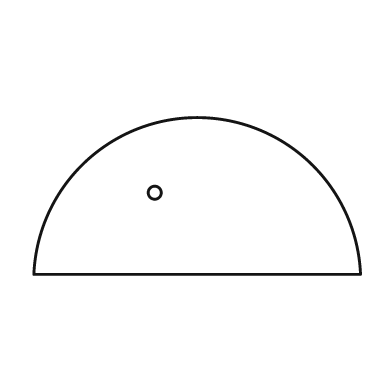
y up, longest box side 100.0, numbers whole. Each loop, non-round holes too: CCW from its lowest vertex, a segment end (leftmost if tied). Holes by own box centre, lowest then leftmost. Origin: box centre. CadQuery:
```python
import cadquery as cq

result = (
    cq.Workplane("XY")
    .moveTo(-50.0, -24.0)
    .lineTo(50.0, -24.0)
    .threePointArc((0.0, 24.0), (-50.0, -24.0))
    .close()
    .moveTo(-13.0, 1.0)
    .circle(2.0)
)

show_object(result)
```